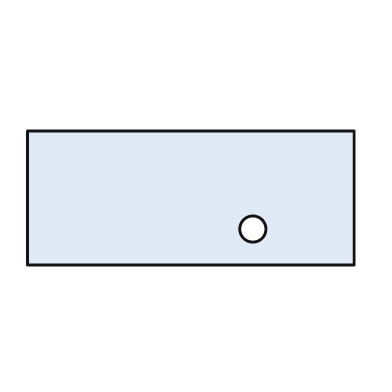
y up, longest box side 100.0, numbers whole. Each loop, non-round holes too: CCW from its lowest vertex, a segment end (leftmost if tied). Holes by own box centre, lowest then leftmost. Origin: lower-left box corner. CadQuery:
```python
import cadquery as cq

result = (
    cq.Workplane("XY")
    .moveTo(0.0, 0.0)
    .lineTo(100.0, 0.0)
    .lineTo(100.0, 41.0)
    .lineTo(0.0, 41.0)
    .close()
    .moveTo(69.0, 11.0)
    .circle(4.0)
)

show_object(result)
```